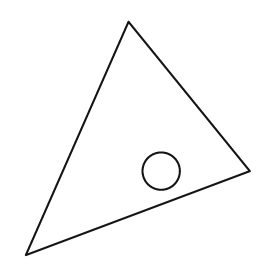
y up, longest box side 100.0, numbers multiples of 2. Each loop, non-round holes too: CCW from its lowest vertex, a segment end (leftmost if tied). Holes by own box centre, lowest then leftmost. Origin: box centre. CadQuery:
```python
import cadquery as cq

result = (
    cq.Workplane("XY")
    .moveTo(-48.0, -50.0)
    .lineTo(48.0, -14.0)
    .lineTo(-4.0, 50.0)
    .close()
    .moveTo(10.0, -14.0)
    .circle(8.0)
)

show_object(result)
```